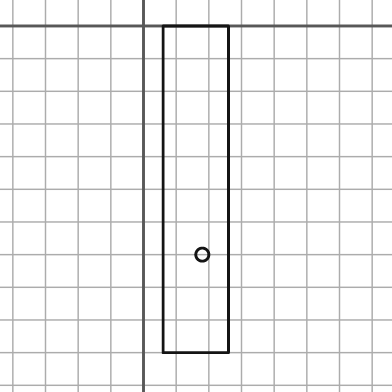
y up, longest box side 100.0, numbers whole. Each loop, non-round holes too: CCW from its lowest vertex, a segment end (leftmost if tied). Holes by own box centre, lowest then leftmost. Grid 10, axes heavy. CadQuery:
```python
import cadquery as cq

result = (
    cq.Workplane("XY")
    .moveTo(6.0, -100.0)
    .lineTo(26.0, -100.0)
    .lineTo(26.0, 0.0)
    .lineTo(6.0, 0.0)
    .close()
    .moveTo(18.0, -70.0)
    .circle(2.0)
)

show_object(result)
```